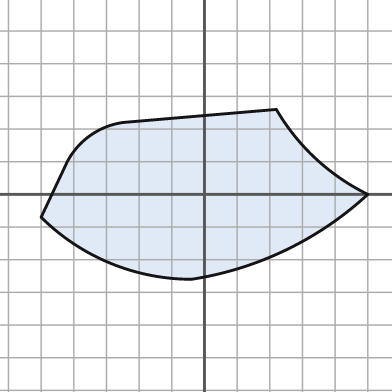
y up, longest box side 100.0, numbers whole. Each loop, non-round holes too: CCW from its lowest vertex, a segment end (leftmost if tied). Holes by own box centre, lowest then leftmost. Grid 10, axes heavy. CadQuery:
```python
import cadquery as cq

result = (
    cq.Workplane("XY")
    .moveTo(-4.0, -26.0)
    .threePointArc((25.0, -17.0), (50.0, 0.0))
    .threePointArc((34.0, 11.0), (22.0, 26.0))
    .lineTo(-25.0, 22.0)
    .threePointArc((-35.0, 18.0), (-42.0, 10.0))
    .lineTo(-50.0, -7.0)
    .threePointArc((-29.0, -21.0), (-4.0, -26.0))
    .close()
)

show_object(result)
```